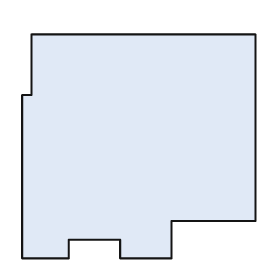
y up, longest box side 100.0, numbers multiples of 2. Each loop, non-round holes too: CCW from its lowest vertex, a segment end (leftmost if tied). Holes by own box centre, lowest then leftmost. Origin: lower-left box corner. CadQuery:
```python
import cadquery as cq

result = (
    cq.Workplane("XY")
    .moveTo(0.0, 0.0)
    .lineTo(20.0, 0.0)
    .lineTo(20.0, 8.0)
    .lineTo(42.0, 8.0)
    .lineTo(42.0, 0.0)
    .lineTo(64.0, 0.0)
    .lineTo(64.0, 16.0)
    .lineTo(100.0, 16.0)
    .lineTo(100.0, 96.0)
    .lineTo(4.0, 96.0)
    .lineTo(4.0, 70.0)
    .lineTo(0.0, 70.0)
    .close()
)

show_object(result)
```